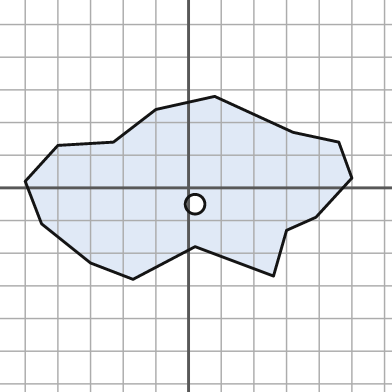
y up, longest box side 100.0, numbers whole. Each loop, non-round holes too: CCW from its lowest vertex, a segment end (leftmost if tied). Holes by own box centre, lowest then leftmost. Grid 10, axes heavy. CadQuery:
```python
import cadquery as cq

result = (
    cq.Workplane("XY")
    .moveTo(-17.0, -28.0)
    .lineTo(2.0, -18.0)
    .lineTo(26.0, -27.0)
    .lineTo(30.0, -13.0)
    .lineTo(39.0, -9.0)
    .lineTo(50.0, 3.0)
    .lineTo(46.0, 14.0)
    .lineTo(32.0, 17.0)
    .lineTo(8.0, 28.0)
    .lineTo(-10.0, 24.0)
    .lineTo(-23.0, 14.0)
    .lineTo(-40.0, 13.0)
    .lineTo(-50.0, 2.0)
    .lineTo(-45.0, -11.0)
    .lineTo(-30.0, -23.0)
    .close()
    .moveTo(2.0, -5.0)
    .circle(3.0)
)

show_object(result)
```